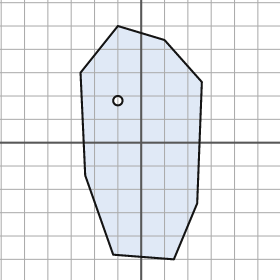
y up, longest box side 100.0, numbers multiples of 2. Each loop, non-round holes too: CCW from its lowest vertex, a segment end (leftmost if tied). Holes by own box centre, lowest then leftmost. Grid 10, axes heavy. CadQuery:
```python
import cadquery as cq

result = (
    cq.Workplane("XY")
    .moveTo(14.0, -50.0)
    .lineTo(24.0, -26.0)
    .lineTo(26.0, 26.0)
    .lineTo(10.0, 44.0)
    .lineTo(-10.0, 50.0)
    .lineTo(-26.0, 30.0)
    .lineTo(-24.0, -14.0)
    .lineTo(-12.0, -48.0)
    .close()
    .moveTo(-10.0, 18.0)
    .circle(2.0)
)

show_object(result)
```